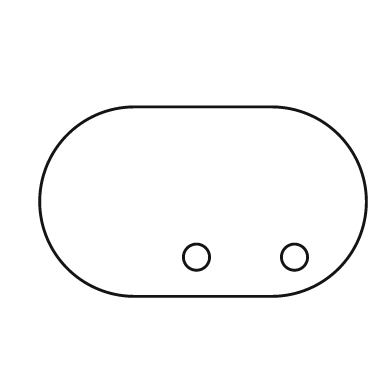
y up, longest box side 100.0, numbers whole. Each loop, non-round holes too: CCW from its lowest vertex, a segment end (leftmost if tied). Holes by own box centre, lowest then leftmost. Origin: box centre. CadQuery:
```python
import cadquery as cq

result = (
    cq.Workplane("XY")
    .moveTo(-21.0, -29.0)
    .lineTo(21.0, -29.0)
    .threePointArc((50.0, 0.0), (21.0, 29.0))
    .lineTo(-21.0, 29.0)
    .threePointArc((-50.0, 0.0), (-21.0, -29.0))
    .close()
    .moveTo(-2.0, -17.0)
    .circle(4.0)
    .moveTo(28.0, -17.0)
    .circle(4.0)
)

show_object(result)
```